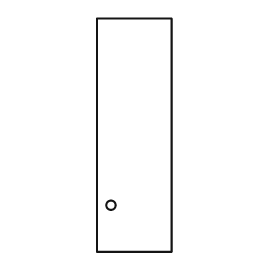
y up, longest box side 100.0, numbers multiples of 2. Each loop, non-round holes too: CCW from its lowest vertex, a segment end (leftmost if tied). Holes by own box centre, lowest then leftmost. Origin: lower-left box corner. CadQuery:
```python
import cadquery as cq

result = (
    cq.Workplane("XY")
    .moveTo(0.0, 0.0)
    .lineTo(32.0, 0.0)
    .lineTo(32.0, 100.0)
    .lineTo(0.0, 100.0)
    .close()
    .moveTo(6.0, 20.0)
    .circle(2.0)
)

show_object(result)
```